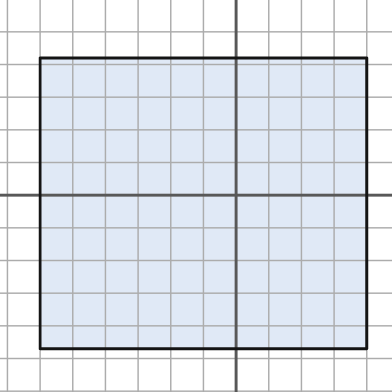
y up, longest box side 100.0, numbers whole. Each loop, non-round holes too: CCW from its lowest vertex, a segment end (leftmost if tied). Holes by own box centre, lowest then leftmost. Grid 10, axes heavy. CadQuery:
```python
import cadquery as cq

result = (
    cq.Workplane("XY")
    .moveTo(-60.0, -47.0)
    .lineTo(40.0, -47.0)
    .lineTo(40.0, 42.0)
    .lineTo(-60.0, 42.0)
    .close()
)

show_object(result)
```